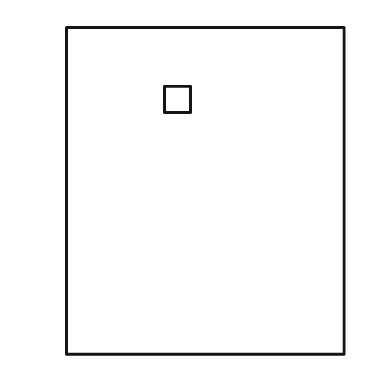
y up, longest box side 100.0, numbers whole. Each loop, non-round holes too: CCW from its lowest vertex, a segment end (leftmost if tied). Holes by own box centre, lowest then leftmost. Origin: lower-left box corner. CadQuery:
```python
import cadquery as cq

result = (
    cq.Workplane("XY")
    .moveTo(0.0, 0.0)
    .lineTo(85.0, 0.0)
    .lineTo(85.0, 100.0)
    .lineTo(0.0, 100.0)
    .close()
    .moveTo(30.0, 74.0)
    .lineTo(38.0, 74.0)
    .lineTo(38.0, 82.0)
    .lineTo(30.0, 82.0)
    .close()
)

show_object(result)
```